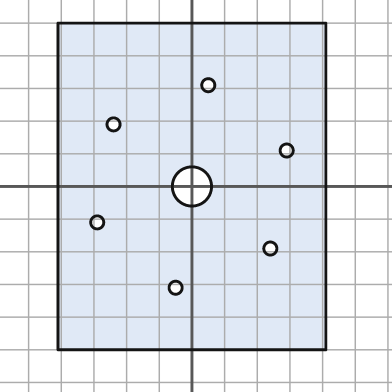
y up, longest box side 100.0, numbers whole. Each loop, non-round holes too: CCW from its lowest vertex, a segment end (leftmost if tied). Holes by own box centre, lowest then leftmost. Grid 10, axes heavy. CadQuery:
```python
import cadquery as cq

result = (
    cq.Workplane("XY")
    .moveTo(-41.0, -50.0)
    .lineTo(41.0, -50.0)
    .lineTo(41.0, 50.0)
    .lineTo(-41.0, 50.0)
    .close()
    .moveTo(-5.0, -31.0)
    .circle(2.0)
    .moveTo(24.0, -19.0)
    .circle(2.0)
    .moveTo(-29.0, -11.0)
    .circle(2.0)
    .moveTo(0.0, 0.0)
    .circle(6.0)
    .moveTo(29.0, 11.0)
    .circle(2.0)
    .moveTo(-24.0, 19.0)
    .circle(2.0)
    .moveTo(5.0, 31.0)
    .circle(2.0)
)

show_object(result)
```